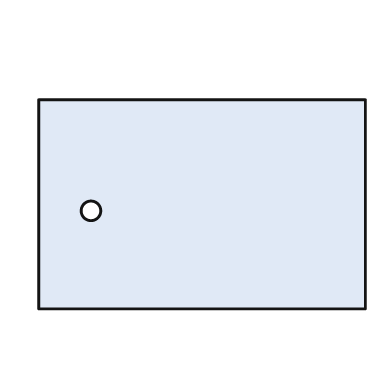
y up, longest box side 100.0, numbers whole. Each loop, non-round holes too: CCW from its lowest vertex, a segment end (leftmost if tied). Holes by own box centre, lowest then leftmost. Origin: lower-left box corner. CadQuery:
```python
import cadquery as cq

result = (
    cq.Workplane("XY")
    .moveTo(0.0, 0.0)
    .lineTo(100.0, 0.0)
    .lineTo(100.0, 64.0)
    .lineTo(0.0, 64.0)
    .close()
    .moveTo(16.0, 30.0)
    .circle(3.0)
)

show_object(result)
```